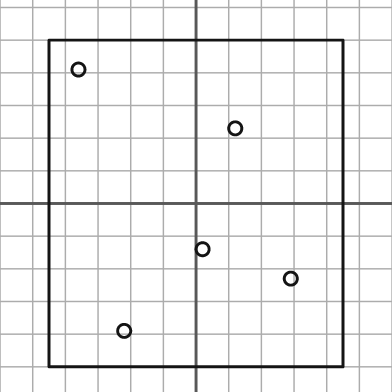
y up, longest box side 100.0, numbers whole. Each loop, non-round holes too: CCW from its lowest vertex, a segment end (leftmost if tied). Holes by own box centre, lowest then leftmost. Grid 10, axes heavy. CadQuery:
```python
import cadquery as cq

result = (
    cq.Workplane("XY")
    .moveTo(-45.0, -50.0)
    .lineTo(45.0, -50.0)
    .lineTo(45.0, 50.0)
    .lineTo(-45.0, 50.0)
    .close()
    .moveTo(-22.0, -39.0)
    .circle(2.0)
    .moveTo(29.0, -23.0)
    .circle(2.0)
    .moveTo(2.0, -14.0)
    .circle(2.0)
    .moveTo(12.0, 23.0)
    .circle(2.0)
    .moveTo(-36.0, 41.0)
    .circle(2.0)
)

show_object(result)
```